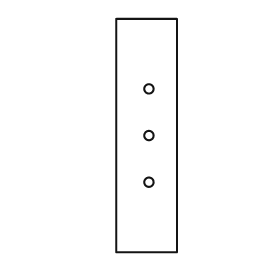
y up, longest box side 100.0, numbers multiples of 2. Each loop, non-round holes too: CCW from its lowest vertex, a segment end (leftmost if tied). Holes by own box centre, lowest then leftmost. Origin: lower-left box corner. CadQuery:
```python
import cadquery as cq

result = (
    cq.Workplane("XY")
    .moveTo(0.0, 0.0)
    .lineTo(26.0, 0.0)
    .lineTo(26.0, 100.0)
    .lineTo(0.0, 100.0)
    .close()
    .moveTo(14.0, 30.0)
    .circle(2.0)
    .moveTo(14.0, 50.0)
    .circle(2.0)
    .moveTo(14.0, 70.0)
    .circle(2.0)
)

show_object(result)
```